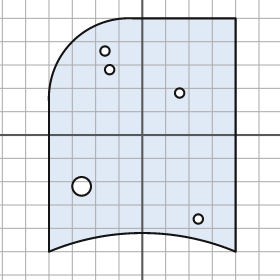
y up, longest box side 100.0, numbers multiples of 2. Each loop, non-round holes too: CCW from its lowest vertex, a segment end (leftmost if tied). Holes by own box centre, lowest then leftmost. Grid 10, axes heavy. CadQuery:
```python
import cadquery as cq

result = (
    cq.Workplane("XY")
    .moveTo(-40.0, -50.0)
    .threePointArc((0.0, -42.0), (40.0, -50.0))
    .lineTo(40.0, 50.0)
    .lineTo(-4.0, 50.0)
    .threePointArc((-30.0, 40.0), (-40.0, 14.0))
    .close()
    .moveTo(24.0, -36.0)
    .circle(2.0)
    .moveTo(-26.0, -22.0)
    .circle(4.0)
    .moveTo(16.0, 18.0)
    .circle(2.0)
    .moveTo(-14.0, 28.0)
    .circle(2.0)
    .moveTo(-16.0, 36.0)
    .circle(2.0)
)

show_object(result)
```